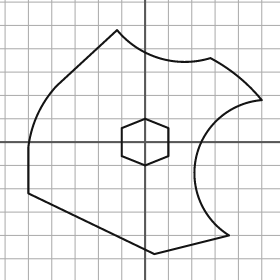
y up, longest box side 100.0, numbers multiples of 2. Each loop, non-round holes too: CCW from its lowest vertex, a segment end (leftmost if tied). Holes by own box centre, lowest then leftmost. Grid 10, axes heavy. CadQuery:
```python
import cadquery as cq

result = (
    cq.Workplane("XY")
    .moveTo(4.0, -48.0)
    .lineTo(36.0, -40.0)
    .threePointArc((22.0, -6.0), (50.0, 18.0))
    .threePointArc((40.0, 28.0), (28.0, 36.0))
    .threePointArc((6.0, 36.0), (-12.0, 48.0))
    .lineTo(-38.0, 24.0)
    .threePointArc((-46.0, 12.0), (-50.0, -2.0))
    .lineTo(-50.0, -22.0)
    .close()
    .moveTo(0.0, -10.0)
    .lineTo(10.0, -6.0)
    .lineTo(10.0, 6.0)
    .lineTo(0.0, 10.0)
    .lineTo(-10.0, 6.0)
    .lineTo(-10.0, -6.0)
    .close()
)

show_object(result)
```